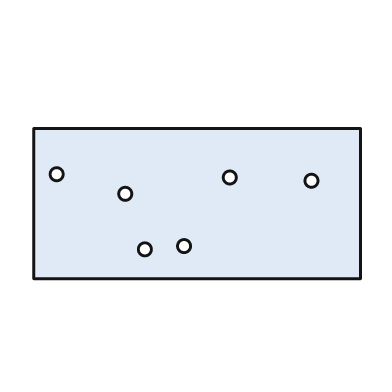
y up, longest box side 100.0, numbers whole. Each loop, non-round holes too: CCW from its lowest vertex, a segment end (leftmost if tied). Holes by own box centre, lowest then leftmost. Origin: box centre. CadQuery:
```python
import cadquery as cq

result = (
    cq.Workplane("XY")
    .moveTo(-50.0, -23.0)
    .lineTo(50.0, -23.0)
    .lineTo(50.0, 23.0)
    .lineTo(-50.0, 23.0)
    .close()
    .moveTo(-16.0, -14.0)
    .circle(2.0)
    .moveTo(-4.0, -13.0)
    .circle(2.0)
    .moveTo(-22.0, 3.0)
    .circle(2.0)
    .moveTo(35.0, 7.0)
    .circle(2.0)
    .moveTo(10.0, 8.0)
    .circle(2.0)
    .moveTo(-43.0, 9.0)
    .circle(2.0)
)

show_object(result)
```